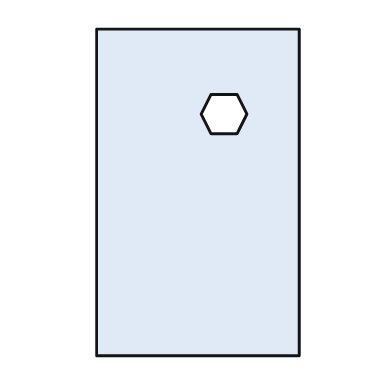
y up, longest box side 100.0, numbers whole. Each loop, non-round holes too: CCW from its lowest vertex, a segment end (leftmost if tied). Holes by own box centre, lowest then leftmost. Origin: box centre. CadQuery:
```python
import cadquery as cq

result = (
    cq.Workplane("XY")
    .moveTo(-31.0, -50.0)
    .lineTo(31.0, -50.0)
    .lineTo(31.0, 50.0)
    .lineTo(-31.0, 50.0)
    .close()
    .moveTo(4.0, 18.0)
    .lineTo(12.0, 18.0)
    .lineTo(15.0, 24.0)
    .lineTo(12.0, 30.0)
    .lineTo(4.0, 30.0)
    .lineTo(1.0, 24.0)
    .close()
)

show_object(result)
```